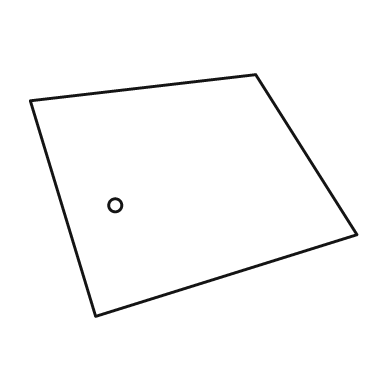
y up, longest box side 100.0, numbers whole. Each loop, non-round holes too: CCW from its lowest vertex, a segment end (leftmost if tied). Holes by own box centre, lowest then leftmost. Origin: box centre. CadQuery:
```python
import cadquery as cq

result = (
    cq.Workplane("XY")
    .moveTo(-30.0, -37.0)
    .lineTo(50.0, -12.0)
    .lineTo(19.0, 37.0)
    .lineTo(-50.0, 29.0)
    .close()
    .moveTo(-24.0, -3.0)
    .circle(2.0)
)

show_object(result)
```